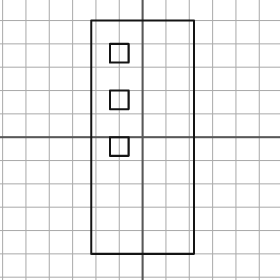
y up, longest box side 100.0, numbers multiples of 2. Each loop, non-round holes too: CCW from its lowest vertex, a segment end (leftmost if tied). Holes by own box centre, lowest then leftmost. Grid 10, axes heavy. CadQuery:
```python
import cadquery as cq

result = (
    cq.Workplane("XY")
    .moveTo(-22.0, -50.0)
    .lineTo(22.0, -50.0)
    .lineTo(22.0, 50.0)
    .lineTo(-22.0, 50.0)
    .close()
    .moveTo(-14.0, -8.0)
    .lineTo(-6.0, -8.0)
    .lineTo(-6.0, 0.0)
    .lineTo(-14.0, 0.0)
    .close()
    .moveTo(-14.0, 12.0)
    .lineTo(-6.0, 12.0)
    .lineTo(-6.0, 20.0)
    .lineTo(-14.0, 20.0)
    .close()
    .moveTo(-14.0, 32.0)
    .lineTo(-6.0, 32.0)
    .lineTo(-6.0, 40.0)
    .lineTo(-14.0, 40.0)
    .close()
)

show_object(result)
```